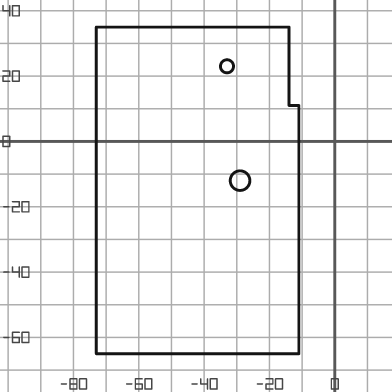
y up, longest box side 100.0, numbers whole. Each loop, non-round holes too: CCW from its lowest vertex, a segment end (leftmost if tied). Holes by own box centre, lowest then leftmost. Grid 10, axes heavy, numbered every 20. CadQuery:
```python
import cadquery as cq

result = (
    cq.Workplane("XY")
    .moveTo(-73.0, -65.0)
    .lineTo(-11.0, -65.0)
    .lineTo(-11.0, 11.0)
    .lineTo(-14.0, 11.0)
    .lineTo(-14.0, 35.0)
    .lineTo(-73.0, 35.0)
    .close()
    .moveTo(-29.0, -12.0)
    .circle(3.0)
    .moveTo(-33.0, 23.0)
    .circle(2.0)
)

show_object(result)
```